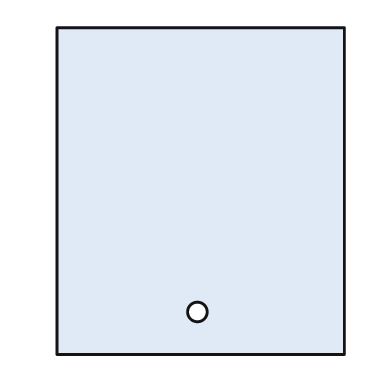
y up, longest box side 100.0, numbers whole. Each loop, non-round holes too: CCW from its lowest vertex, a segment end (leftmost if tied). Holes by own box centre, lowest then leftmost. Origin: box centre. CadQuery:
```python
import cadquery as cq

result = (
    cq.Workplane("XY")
    .moveTo(-44.0, -50.0)
    .lineTo(44.0, -50.0)
    .lineTo(44.0, 50.0)
    .lineTo(-44.0, 50.0)
    .close()
    .moveTo(-1.0, -37.0)
    .circle(3.0)
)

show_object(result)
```